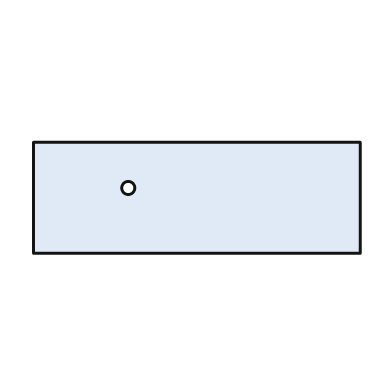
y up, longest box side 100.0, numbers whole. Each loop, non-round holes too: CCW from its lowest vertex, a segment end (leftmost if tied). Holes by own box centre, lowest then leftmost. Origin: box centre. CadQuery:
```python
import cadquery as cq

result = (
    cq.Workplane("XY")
    .moveTo(-50.0, -17.0)
    .lineTo(50.0, -17.0)
    .lineTo(50.0, 17.0)
    .lineTo(-50.0, 17.0)
    .close()
    .moveTo(-21.0, 3.0)
    .circle(2.0)
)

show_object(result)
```